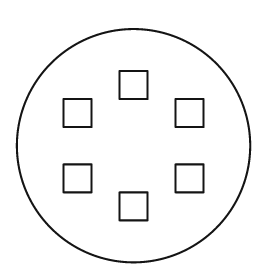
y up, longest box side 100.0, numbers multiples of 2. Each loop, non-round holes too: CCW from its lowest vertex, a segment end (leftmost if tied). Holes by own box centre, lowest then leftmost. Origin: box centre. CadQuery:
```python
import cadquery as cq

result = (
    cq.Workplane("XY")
    .moveTo(0.0, 0.0)
    .circle(50.0)
    .moveTo(-6.0, -32.0)
    .lineTo(6.0, -32.0)
    .lineTo(6.0, -20.0)
    .lineTo(-6.0, -20.0)
    .close()
    .moveTo(-30.0, -20.0)
    .lineTo(-18.0, -20.0)
    .lineTo(-18.0, -8.0)
    .lineTo(-30.0, -8.0)
    .close()
    .moveTo(18.0, -20.0)
    .lineTo(30.0, -20.0)
    .lineTo(30.0, -8.0)
    .lineTo(18.0, -8.0)
    .close()
    .moveTo(-30.0, 8.0)
    .lineTo(-18.0, 8.0)
    .lineTo(-18.0, 20.0)
    .lineTo(-30.0, 20.0)
    .close()
    .moveTo(18.0, 8.0)
    .lineTo(30.0, 8.0)
    .lineTo(30.0, 20.0)
    .lineTo(18.0, 20.0)
    .close()
    .moveTo(-6.0, 20.0)
    .lineTo(6.0, 20.0)
    .lineTo(6.0, 32.0)
    .lineTo(-6.0, 32.0)
    .close()
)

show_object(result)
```